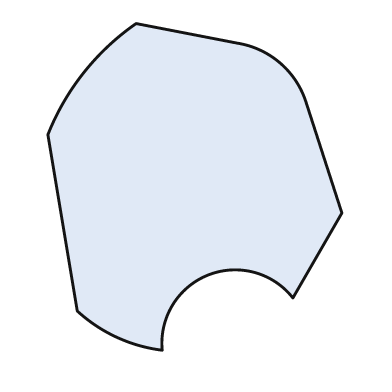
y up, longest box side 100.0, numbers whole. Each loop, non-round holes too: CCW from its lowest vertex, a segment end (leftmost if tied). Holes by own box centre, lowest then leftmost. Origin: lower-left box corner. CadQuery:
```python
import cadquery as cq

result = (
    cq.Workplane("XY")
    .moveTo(35.0, 0.0)
    .threePointArc((49.0, 23.0), (75.0, 16.0))
    .lineTo(90.0, 42.0)
    .lineTo(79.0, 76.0)
    .threePointArc((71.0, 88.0), (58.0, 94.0))
    .lineTo(27.0, 100.0)
    .threePointArc((11.0, 85.0), (0.0, 66.0))
    .lineTo(9.0, 12.0)
    .threePointArc((21.0, 4.0), (35.0, 0.0))
    .close()
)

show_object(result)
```